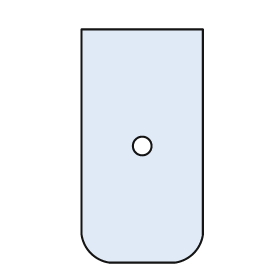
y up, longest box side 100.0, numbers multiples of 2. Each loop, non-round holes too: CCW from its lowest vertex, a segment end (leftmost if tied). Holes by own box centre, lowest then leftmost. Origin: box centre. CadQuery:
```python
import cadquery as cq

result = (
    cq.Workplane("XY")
    .moveTo(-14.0, -50.0)
    .lineTo(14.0, -50.0)
    .threePointArc((22.0, -46.0), (26.0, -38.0))
    .lineTo(26.0, 50.0)
    .lineTo(-26.0, 50.0)
    .lineTo(-26.0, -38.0)
    .threePointArc((-22.0, -46.0), (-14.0, -50.0))
    .close()
    .moveTo(0.0, 0.0)
    .circle(4.0)
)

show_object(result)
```